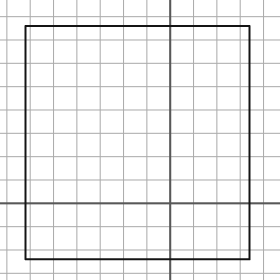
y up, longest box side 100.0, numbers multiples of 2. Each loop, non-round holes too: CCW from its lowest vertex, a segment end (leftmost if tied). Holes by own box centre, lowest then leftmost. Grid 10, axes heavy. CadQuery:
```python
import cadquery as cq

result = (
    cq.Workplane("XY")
    .moveTo(-62.0, -24.0)
    .lineTo(34.0, -24.0)
    .lineTo(34.0, 76.0)
    .lineTo(-62.0, 76.0)
    .close()
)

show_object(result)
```